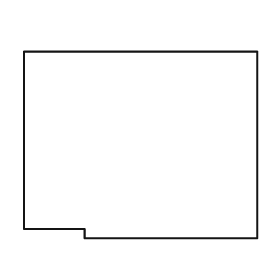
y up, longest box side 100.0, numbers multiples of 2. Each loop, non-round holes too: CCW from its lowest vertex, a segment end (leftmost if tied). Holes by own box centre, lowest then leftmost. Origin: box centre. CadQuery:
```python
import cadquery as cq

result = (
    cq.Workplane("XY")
    .moveTo(-24.0, -40.0)
    .lineTo(50.0, -40.0)
    .lineTo(50.0, 40.0)
    .lineTo(-50.0, 40.0)
    .lineTo(-50.0, -36.0)
    .lineTo(-24.0, -36.0)
    .close()
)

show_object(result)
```